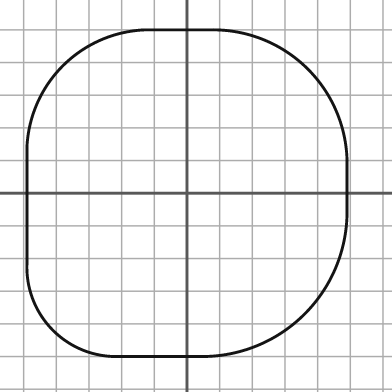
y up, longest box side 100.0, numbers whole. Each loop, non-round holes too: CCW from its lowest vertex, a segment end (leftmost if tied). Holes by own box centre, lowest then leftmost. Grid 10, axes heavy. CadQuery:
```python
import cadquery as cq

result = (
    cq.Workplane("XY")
    .moveTo(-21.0, -50.0)
    .lineTo(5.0, -50.0)
    .threePointArc((36.0, -37.0), (49.0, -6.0))
    .lineTo(49.0, 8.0)
    .threePointArc((37.0, 38.0), (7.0, 50.0))
    .lineTo(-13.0, 50.0)
    .threePointArc((-38.0, 39.0), (-49.0, 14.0))
    .lineTo(-49.0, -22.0)
    .threePointArc((-41.0, -42.0), (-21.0, -50.0))
    .close()
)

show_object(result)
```